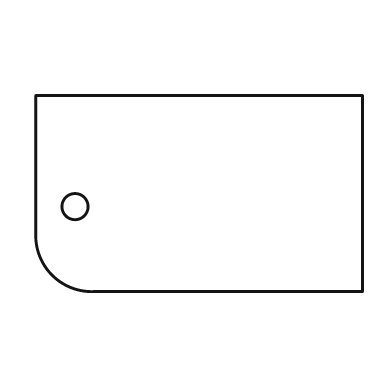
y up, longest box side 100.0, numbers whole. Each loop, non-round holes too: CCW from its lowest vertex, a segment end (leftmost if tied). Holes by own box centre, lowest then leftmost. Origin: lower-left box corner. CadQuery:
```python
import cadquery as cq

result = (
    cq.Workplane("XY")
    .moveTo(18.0, 0.0)
    .lineTo(100.0, 0.0)
    .lineTo(100.0, 60.0)
    .lineTo(0.0, 60.0)
    .lineTo(0.0, 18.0)
    .threePointArc((5.0, 5.0), (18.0, 0.0))
    .close()
    .moveTo(12.0, 26.0)
    .circle(4.0)
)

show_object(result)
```